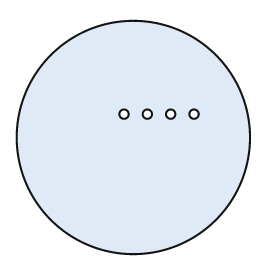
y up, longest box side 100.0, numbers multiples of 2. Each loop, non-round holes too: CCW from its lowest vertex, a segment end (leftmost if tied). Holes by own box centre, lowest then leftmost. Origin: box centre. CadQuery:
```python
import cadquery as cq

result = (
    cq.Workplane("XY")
    .moveTo(0.0, 0.0)
    .circle(50.0)
    .moveTo(-4.0, 10.0)
    .circle(2.0)
    .moveTo(6.0, 10.0)
    .circle(2.0)
    .moveTo(16.0, 10.0)
    .circle(2.0)
    .moveTo(26.0, 10.0)
    .circle(2.0)
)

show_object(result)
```